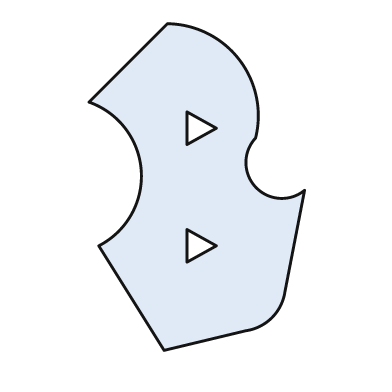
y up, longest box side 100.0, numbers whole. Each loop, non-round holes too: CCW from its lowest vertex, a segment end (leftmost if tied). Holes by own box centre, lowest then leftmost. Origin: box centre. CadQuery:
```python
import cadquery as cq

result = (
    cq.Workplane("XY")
    .moveTo(-10.0, -50.0)
    .lineTo(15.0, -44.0)
    .threePointArc((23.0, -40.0), (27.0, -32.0))
    .lineTo(33.0, -1.0)
    .threePointArc((18.0, 0.0), (18.0, 15.0))
    .threePointArc((13.0, 39.0), (-9.0, 50.0))
    .lineTo(-33.0, 26.0)
    .threePointArc((-17.0, 5.0), (-30.0, -18.0))
    .close()
    .moveTo(-3.0, -23.0)
    .lineTo(6.0, -18.0)
    .lineTo(-3.0, -13.0)
    .close()
    .moveTo(-3.0, 13.0)
    .lineTo(6.0, 18.0)
    .lineTo(-3.0, 23.0)
    .close()
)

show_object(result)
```